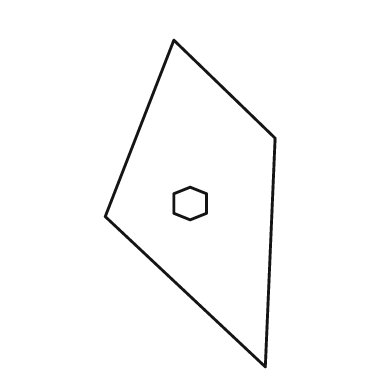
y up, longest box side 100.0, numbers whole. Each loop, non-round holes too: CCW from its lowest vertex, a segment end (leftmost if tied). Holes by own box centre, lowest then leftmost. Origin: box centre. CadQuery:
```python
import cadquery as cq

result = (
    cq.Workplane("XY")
    .moveTo(23.0, -50.0)
    .lineTo(26.0, 20.0)
    .lineTo(-5.0, 50.0)
    .lineTo(-26.0, -4.0)
    .close()
    .moveTo(0.0, -5.0)
    .lineTo(5.0, -3.0)
    .lineTo(5.0, 3.0)
    .lineTo(0.0, 5.0)
    .lineTo(-5.0, 3.0)
    .lineTo(-5.0, -3.0)
    .close()
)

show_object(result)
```